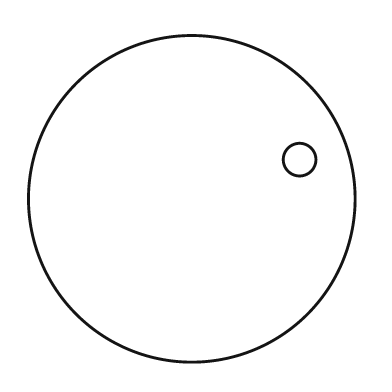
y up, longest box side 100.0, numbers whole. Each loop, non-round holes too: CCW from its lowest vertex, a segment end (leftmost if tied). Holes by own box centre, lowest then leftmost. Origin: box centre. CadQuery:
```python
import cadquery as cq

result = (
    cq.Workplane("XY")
    .moveTo(0.0, 0.0)
    .circle(50.0)
    .moveTo(33.0, 12.0)
    .circle(5.0)
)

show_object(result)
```